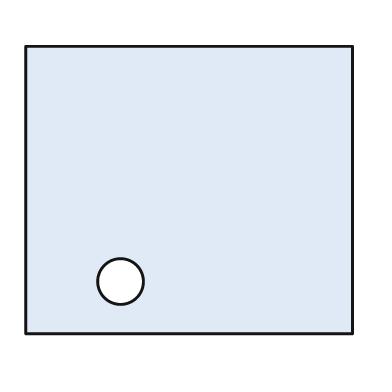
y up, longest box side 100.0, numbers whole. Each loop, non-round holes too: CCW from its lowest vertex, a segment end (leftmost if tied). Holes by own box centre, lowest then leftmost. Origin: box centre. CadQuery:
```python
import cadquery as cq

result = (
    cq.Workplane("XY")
    .moveTo(-50.0, -44.0)
    .lineTo(50.0, -44.0)
    .lineTo(50.0, 44.0)
    .lineTo(-50.0, 44.0)
    .close()
    .moveTo(-21.0, -28.0)
    .circle(7.0)
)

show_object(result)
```